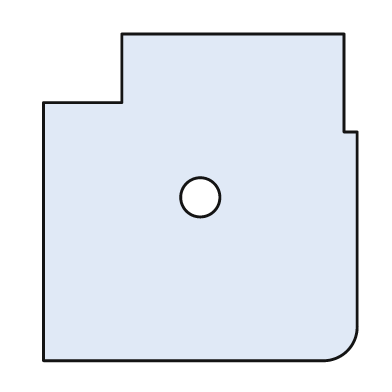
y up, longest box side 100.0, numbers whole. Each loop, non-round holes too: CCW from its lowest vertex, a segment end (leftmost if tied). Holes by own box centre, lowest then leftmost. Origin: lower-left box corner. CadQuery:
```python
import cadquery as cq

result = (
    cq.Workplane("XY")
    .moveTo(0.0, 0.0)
    .lineTo(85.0, 0.0)
    .threePointArc((93.0, 3.0), (96.0, 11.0))
    .lineTo(96.0, 70.0)
    .lineTo(92.0, 70.0)
    .lineTo(92.0, 100.0)
    .lineTo(24.0, 100.0)
    .lineTo(24.0, 79.0)
    .lineTo(0.0, 79.0)
    .close()
    .moveTo(48.0, 50.0)
    .circle(6.0)
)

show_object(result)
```